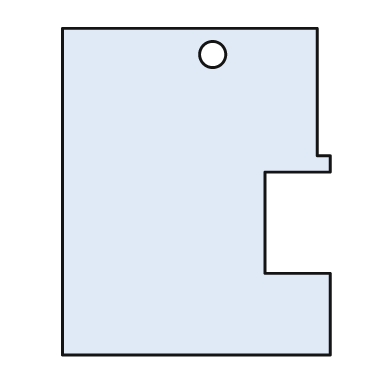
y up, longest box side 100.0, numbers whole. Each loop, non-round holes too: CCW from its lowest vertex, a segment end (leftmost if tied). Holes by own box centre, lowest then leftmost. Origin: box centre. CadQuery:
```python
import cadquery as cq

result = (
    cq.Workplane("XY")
    .moveTo(-41.0, -50.0)
    .lineTo(41.0, -50.0)
    .lineTo(41.0, -25.0)
    .lineTo(21.0, -25.0)
    .lineTo(21.0, 6.0)
    .lineTo(41.0, 6.0)
    .lineTo(41.0, 11.0)
    .lineTo(37.0, 11.0)
    .lineTo(37.0, 50.0)
    .lineTo(-41.0, 50.0)
    .close()
    .moveTo(5.0, 42.0)
    .circle(4.0)
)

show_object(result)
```